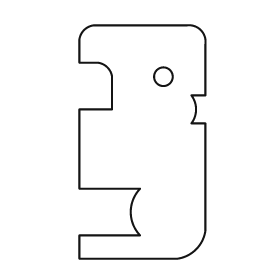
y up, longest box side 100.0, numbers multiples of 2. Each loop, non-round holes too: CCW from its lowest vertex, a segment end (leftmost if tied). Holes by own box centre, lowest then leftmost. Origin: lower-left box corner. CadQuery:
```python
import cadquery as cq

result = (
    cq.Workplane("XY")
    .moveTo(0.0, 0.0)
    .lineTo(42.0, 0.0)
    .threePointArc((50.0, 4.0), (54.0, 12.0))
    .lineTo(54.0, 58.0)
    .lineTo(48.0, 58.0)
    .threePointArc((50.0, 64.0), (48.0, 70.0))
    .lineTo(54.0, 70.0)
    .lineTo(54.0, 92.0)
    .threePointArc((52.0, 98.0), (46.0, 100.0))
    .lineTo(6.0, 100.0)
    .threePointArc((2.0, 98.0), (0.0, 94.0))
    .lineTo(0.0, 84.0)
    .lineTo(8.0, 84.0)
    .threePointArc((12.0, 82.0), (14.0, 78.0))
    .lineTo(14.0, 64.0)
    .lineTo(0.0, 64.0)
    .lineTo(0.0, 30.0)
    .lineTo(26.0, 30.0)
    .threePointArc((22.0, 20.0), (26.0, 10.0))
    .lineTo(0.0, 10.0)
    .close()
    .moveTo(36.0, 78.0)
    .circle(4.0)
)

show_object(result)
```